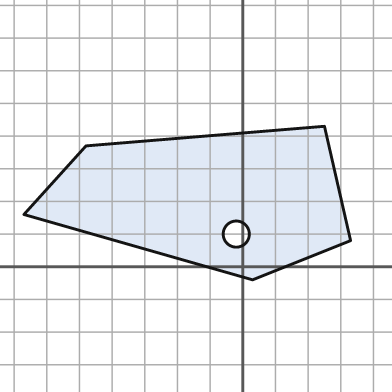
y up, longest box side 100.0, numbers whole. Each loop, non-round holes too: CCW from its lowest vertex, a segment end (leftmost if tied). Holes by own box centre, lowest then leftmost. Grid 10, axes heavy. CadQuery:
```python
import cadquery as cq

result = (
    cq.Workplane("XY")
    .moveTo(3.0, -4.0)
    .lineTo(33.0, 8.0)
    .lineTo(25.0, 43.0)
    .lineTo(-48.0, 37.0)
    .lineTo(-67.0, 16.0)
    .close()
    .moveTo(-2.0, 10.0)
    .circle(4.0)
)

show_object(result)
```